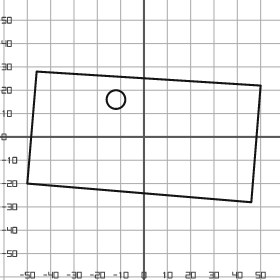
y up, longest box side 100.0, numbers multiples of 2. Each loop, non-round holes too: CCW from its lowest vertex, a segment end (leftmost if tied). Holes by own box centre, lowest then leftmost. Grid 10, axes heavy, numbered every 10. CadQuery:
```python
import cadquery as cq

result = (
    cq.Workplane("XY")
    .moveTo(46.0, -28.0)
    .lineTo(50.0, 22.0)
    .lineTo(-46.0, 28.0)
    .lineTo(-50.0, -20.0)
    .close()
    .moveTo(-12.0, 16.0)
    .circle(4.0)
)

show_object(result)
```